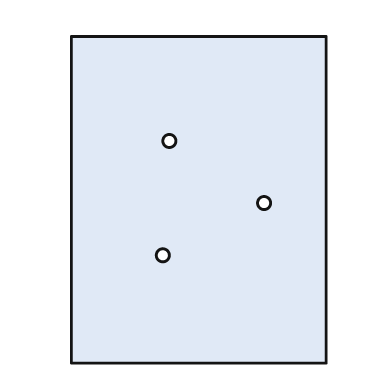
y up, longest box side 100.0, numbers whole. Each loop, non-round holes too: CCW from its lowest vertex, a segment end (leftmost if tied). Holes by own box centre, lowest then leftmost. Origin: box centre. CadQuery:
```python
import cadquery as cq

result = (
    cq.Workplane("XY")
    .moveTo(-39.0, -50.0)
    .lineTo(39.0, -50.0)
    .lineTo(39.0, 50.0)
    .lineTo(-39.0, 50.0)
    .close()
    .moveTo(-11.0, -17.0)
    .circle(2.0)
    .moveTo(20.0, -1.0)
    .circle(2.0)
    .moveTo(-9.0, 18.0)
    .circle(2.0)
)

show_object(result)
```